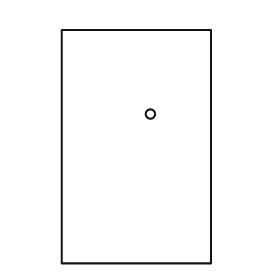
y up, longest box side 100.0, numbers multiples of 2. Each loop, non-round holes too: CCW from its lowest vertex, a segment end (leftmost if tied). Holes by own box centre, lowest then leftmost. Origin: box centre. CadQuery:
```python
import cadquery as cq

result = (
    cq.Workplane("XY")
    .moveTo(-32.0, -50.0)
    .lineTo(32.0, -50.0)
    .lineTo(32.0, 50.0)
    .lineTo(-32.0, 50.0)
    .close()
    .moveTo(6.0, 14.0)
    .circle(2.0)
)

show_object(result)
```